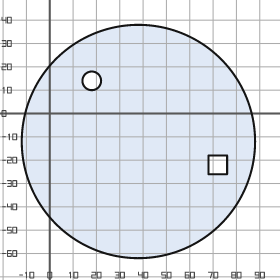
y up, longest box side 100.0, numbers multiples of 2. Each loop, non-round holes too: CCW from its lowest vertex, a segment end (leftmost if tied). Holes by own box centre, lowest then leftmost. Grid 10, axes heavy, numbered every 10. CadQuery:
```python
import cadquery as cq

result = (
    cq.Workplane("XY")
    .moveTo(38.0, -12.0)
    .circle(50.0)
    .moveTo(68.0, -26.0)
    .lineTo(76.0, -26.0)
    .lineTo(76.0, -18.0)
    .lineTo(68.0, -18.0)
    .close()
    .moveTo(18.0, 14.0)
    .circle(4.0)
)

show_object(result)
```